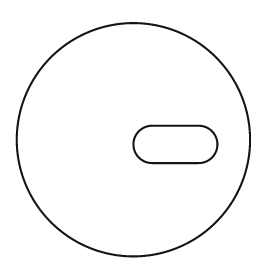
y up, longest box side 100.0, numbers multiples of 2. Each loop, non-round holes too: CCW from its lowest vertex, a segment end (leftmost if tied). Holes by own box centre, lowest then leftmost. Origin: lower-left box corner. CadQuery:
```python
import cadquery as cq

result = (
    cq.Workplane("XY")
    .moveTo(50.0, 50.0)
    .circle(50.0)
    .moveTo(58.0, 40.0)
    .lineTo(78.0, 40.0)
    .threePointArc((86.0, 48.0), (78.0, 56.0))
    .lineTo(58.0, 56.0)
    .threePointArc((50.0, 48.0), (58.0, 40.0))
    .close()
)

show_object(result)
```